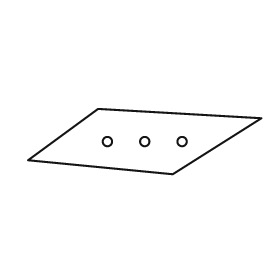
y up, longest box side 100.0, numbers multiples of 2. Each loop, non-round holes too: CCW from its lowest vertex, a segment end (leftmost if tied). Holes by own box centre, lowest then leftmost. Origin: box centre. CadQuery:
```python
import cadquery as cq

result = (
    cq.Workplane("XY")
    .moveTo(12.0, -14.0)
    .lineTo(50.0, 10.0)
    .lineTo(-20.0, 14.0)
    .lineTo(-50.0, -8.0)
    .close()
    .moveTo(-16.0, 0.0)
    .circle(2.0)
    .moveTo(0.0, 0.0)
    .circle(2.0)
    .moveTo(16.0, 0.0)
    .circle(2.0)
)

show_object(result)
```